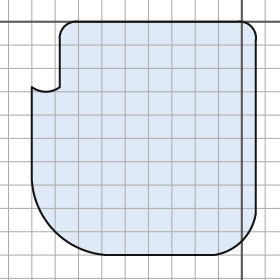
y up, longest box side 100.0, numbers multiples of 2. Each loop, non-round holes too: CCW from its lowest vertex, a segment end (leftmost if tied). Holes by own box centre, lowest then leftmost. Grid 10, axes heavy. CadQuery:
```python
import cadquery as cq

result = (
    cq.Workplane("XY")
    .moveTo(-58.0, -100.0)
    .lineTo(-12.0, -100.0)
    .threePointArc((0.0, -94.0), (6.0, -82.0))
    .lineTo(6.0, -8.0)
    .threePointArc((4.0, -2.0), (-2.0, 0.0))
    .lineTo(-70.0, 0.0)
    .threePointArc((-76.0, -2.0), (-78.0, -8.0))
    .lineTo(-78.0, -28.0)
    .threePointArc((-84.0, -30.0), (-90.0, -28.0))
    .lineTo(-90.0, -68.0)
    .threePointArc((-80.0, -90.0), (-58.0, -100.0))
    .close()
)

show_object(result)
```